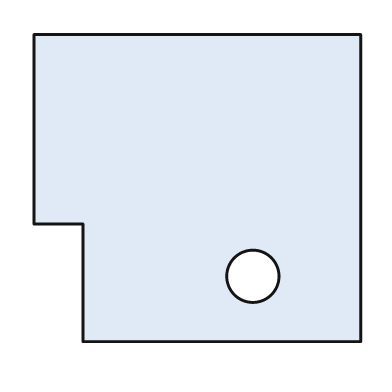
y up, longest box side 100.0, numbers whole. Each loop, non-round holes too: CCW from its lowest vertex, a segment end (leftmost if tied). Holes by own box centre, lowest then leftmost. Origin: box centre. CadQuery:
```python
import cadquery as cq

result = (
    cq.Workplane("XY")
    .moveTo(-35.0, -47.0)
    .lineTo(50.0, -47.0)
    .lineTo(50.0, 47.0)
    .lineTo(-50.0, 47.0)
    .lineTo(-50.0, -11.0)
    .lineTo(-35.0, -11.0)
    .close()
    .moveTo(17.0, -27.0)
    .circle(8.0)
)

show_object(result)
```